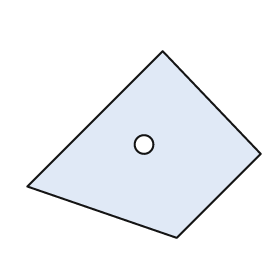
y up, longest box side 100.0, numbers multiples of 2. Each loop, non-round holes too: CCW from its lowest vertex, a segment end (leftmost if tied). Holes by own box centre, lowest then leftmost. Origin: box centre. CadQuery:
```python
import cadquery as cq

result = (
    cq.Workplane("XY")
    .moveTo(14.0, -40.0)
    .lineTo(50.0, -4.0)
    .lineTo(8.0, 40.0)
    .lineTo(-50.0, -18.0)
    .close()
    .moveTo(0.0, 0.0)
    .circle(4.0)
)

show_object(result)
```